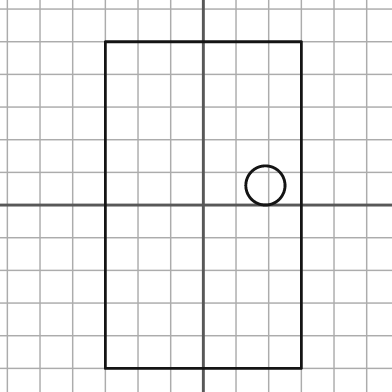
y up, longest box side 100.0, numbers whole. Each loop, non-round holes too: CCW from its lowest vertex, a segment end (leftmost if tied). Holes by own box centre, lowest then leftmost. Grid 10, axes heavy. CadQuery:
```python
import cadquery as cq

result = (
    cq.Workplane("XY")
    .moveTo(-30.0, -50.0)
    .lineTo(30.0, -50.0)
    .lineTo(30.0, 50.0)
    .lineTo(-30.0, 50.0)
    .close()
    .moveTo(19.0, 6.0)
    .circle(6.0)
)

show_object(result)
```